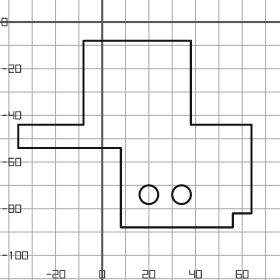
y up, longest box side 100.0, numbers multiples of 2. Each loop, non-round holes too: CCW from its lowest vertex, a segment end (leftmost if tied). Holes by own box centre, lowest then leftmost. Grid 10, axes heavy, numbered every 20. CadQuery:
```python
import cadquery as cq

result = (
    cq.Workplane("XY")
    .moveTo(8.0, -88.0)
    .lineTo(56.0, -88.0)
    .lineTo(56.0, -82.0)
    .lineTo(64.0, -82.0)
    .lineTo(64.0, -44.0)
    .lineTo(38.0, -44.0)
    .lineTo(38.0, -8.0)
    .lineTo(-8.0, -8.0)
    .lineTo(-8.0, -44.0)
    .lineTo(-36.0, -44.0)
    .lineTo(-36.0, -54.0)
    .lineTo(8.0, -54.0)
    .close()
    .moveTo(20.0, -74.0)
    .circle(4.0)
    .moveTo(34.0, -74.0)
    .circle(4.0)
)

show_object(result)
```